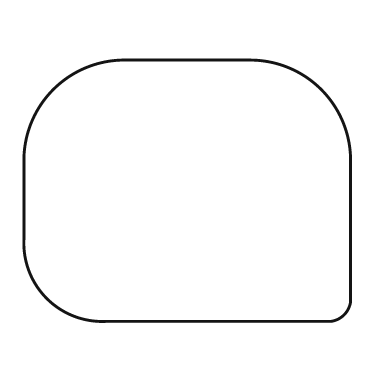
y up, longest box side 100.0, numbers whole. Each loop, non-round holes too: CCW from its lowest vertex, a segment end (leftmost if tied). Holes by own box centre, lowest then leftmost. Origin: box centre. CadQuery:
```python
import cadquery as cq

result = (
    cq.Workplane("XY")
    .moveTo(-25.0, -40.0)
    .lineTo(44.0, -40.0)
    .threePointArc((48.0, -38.0), (50.0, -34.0))
    .lineTo(50.0, 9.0)
    .threePointArc((41.0, 31.0), (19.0, 40.0))
    .lineTo(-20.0, 40.0)
    .threePointArc((-41.0, 31.0), (-50.0, 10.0))
    .lineTo(-50.0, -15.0)
    .threePointArc((-43.0, -33.0), (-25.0, -40.0))
    .close()
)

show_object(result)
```